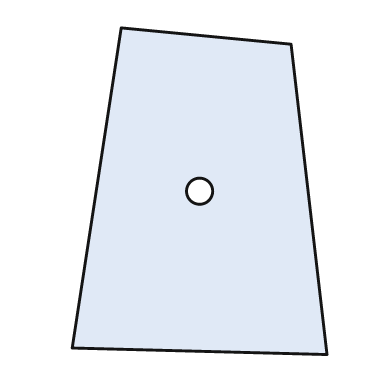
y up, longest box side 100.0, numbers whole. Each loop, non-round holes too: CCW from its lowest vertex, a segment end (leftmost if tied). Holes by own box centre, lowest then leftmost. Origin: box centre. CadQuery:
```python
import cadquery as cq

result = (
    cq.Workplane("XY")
    .moveTo(39.0, -50.0)
    .lineTo(28.0, 45.0)
    .lineTo(-24.0, 50.0)
    .lineTo(-39.0, -48.0)
    .close()
    .moveTo(0.0, 0.0)
    .circle(4.0)
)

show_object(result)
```